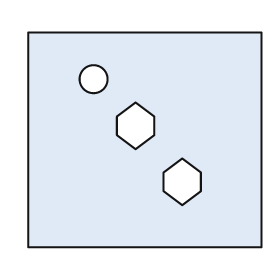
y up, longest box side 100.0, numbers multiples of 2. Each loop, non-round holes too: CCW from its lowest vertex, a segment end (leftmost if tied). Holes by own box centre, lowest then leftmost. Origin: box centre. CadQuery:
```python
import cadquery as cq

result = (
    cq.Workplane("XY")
    .moveTo(-50.0, -46.0)
    .lineTo(50.0, -46.0)
    .lineTo(50.0, 46.0)
    .lineTo(-50.0, 46.0)
    .close()
    .moveTo(16.0, -28.0)
    .lineTo(24.0, -22.0)
    .lineTo(24.0, -14.0)
    .lineTo(16.0, -8.0)
    .lineTo(8.0, -14.0)
    .lineTo(8.0, -22.0)
    .close()
    .moveTo(-4.0, -4.0)
    .lineTo(4.0, 2.0)
    .lineTo(4.0, 10.0)
    .lineTo(-4.0, 16.0)
    .lineTo(-12.0, 10.0)
    .lineTo(-12.0, 2.0)
    .close()
    .moveTo(-22.0, 26.0)
    .circle(6.0)
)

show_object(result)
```